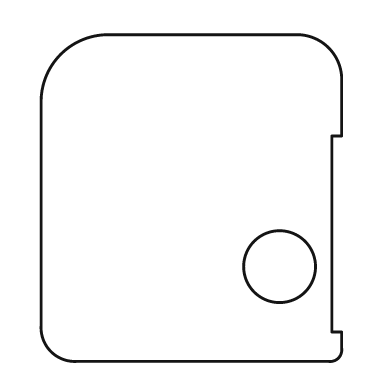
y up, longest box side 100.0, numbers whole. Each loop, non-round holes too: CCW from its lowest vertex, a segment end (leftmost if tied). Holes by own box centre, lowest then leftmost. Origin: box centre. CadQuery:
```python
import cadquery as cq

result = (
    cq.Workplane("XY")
    .moveTo(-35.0, -50.0)
    .lineTo(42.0, -50.0)
    .threePointArc((45.0, -49.0), (46.0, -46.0))
    .lineTo(46.0, -41.0)
    .lineTo(43.0, -41.0)
    .lineTo(43.0, 19.0)
    .lineTo(46.0, 19.0)
    .lineTo(46.0, 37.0)
    .threePointArc((42.0, 46.0), (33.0, 50.0))
    .lineTo(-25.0, 50.0)
    .threePointArc((-40.0, 44.0), (-46.0, 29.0))
    .lineTo(-46.0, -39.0)
    .threePointArc((-43.0, -47.0), (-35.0, -50.0))
    .close()
    .moveTo(27.0, -21.0)
    .circle(11.0)
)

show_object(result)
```